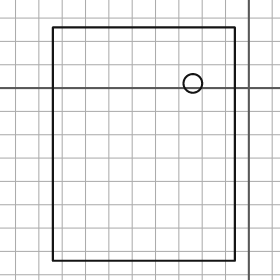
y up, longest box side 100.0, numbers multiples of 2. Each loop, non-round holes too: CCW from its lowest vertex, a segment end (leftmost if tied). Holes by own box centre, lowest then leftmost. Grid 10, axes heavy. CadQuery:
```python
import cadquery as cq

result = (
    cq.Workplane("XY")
    .moveTo(-84.0, -74.0)
    .lineTo(-6.0, -74.0)
    .lineTo(-6.0, 26.0)
    .lineTo(-84.0, 26.0)
    .close()
    .moveTo(-24.0, 2.0)
    .circle(4.0)
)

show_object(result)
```